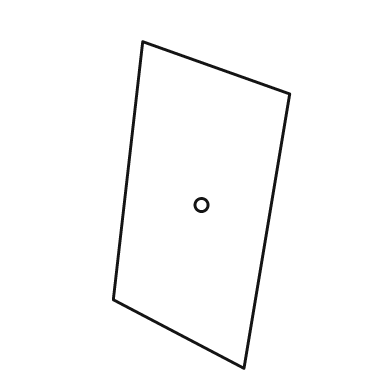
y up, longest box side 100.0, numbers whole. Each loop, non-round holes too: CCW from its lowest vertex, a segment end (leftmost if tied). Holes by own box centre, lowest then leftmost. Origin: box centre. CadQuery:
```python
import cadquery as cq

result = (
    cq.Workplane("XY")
    .moveTo(13.0, -50.0)
    .lineTo(27.0, 34.0)
    .lineTo(-18.0, 50.0)
    .lineTo(-27.0, -29.0)
    .close()
    .moveTo(0.0, 0.0)
    .circle(2.0)
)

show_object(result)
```